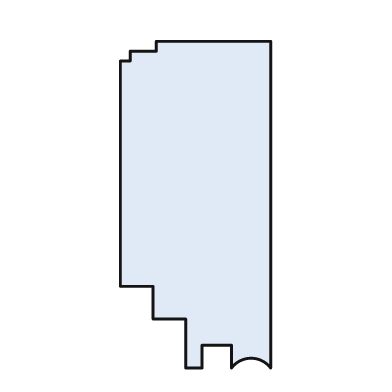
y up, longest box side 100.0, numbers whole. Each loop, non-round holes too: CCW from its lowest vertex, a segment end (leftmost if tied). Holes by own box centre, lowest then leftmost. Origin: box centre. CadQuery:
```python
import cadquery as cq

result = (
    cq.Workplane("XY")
    .moveTo(-3.0, -50.0)
    .lineTo(2.0, -50.0)
    .lineTo(2.0, -43.0)
    .lineTo(11.0, -43.0)
    .lineTo(11.0, -50.0)
    .threePointArc((17.0, -47.0), (23.0, -50.0))
    .lineTo(23.0, 50.0)
    .lineTo(-12.0, 50.0)
    .lineTo(-12.0, 47.0)
    .lineTo(-20.0, 47.0)
    .lineTo(-20.0, 44.0)
    .lineTo(-23.0, 44.0)
    .lineTo(-23.0, -25.0)
    .lineTo(-13.0, -25.0)
    .lineTo(-13.0, -35.0)
    .lineTo(-3.0, -35.0)
    .close()
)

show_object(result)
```